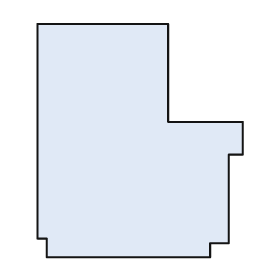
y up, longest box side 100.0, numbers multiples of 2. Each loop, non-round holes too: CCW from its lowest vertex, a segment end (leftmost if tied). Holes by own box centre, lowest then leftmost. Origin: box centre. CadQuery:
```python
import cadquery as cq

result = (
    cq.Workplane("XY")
    .moveTo(-40.0, -50.0)
    .lineTo(30.0, -50.0)
    .lineTo(30.0, -44.0)
    .lineTo(38.0, -44.0)
    .lineTo(38.0, -6.0)
    .lineTo(44.0, -6.0)
    .lineTo(44.0, 8.0)
    .lineTo(12.0, 8.0)
    .lineTo(12.0, 50.0)
    .lineTo(-44.0, 50.0)
    .lineTo(-44.0, -42.0)
    .lineTo(-40.0, -42.0)
    .close()
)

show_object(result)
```